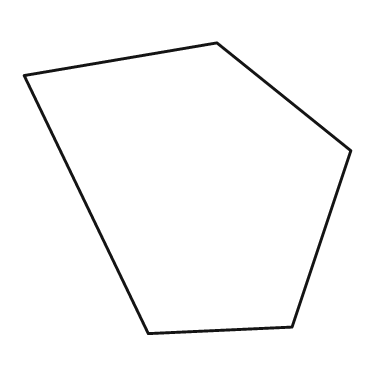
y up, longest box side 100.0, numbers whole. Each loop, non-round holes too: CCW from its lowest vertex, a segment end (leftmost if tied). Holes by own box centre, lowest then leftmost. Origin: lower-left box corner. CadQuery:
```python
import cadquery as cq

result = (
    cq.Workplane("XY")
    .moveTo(38.0, 0.0)
    .lineTo(82.0, 2.0)
    .lineTo(100.0, 56.0)
    .lineTo(59.0, 89.0)
    .lineTo(0.0, 79.0)
    .close()
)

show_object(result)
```